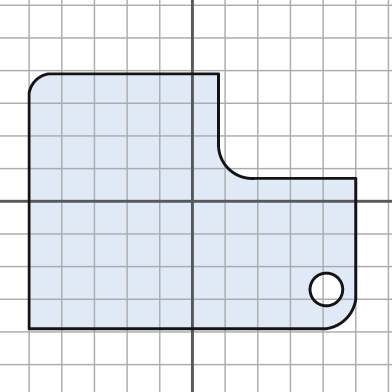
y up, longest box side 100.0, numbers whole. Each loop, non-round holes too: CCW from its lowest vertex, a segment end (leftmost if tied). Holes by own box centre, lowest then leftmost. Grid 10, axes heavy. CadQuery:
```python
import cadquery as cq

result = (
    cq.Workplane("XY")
    .moveTo(-50.0, -39.0)
    .lineTo(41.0, -39.0)
    .threePointArc((47.0, -36.0), (50.0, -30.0))
    .lineTo(50.0, 7.0)
    .lineTo(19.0, 7.0)
    .threePointArc((11.0, 10.0), (8.0, 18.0))
    .lineTo(8.0, 39.0)
    .lineTo(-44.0, 39.0)
    .threePointArc((-48.0, 37.0), (-50.0, 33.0))
    .close()
    .moveTo(41.0, -27.0)
    .circle(5.0)
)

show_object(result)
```